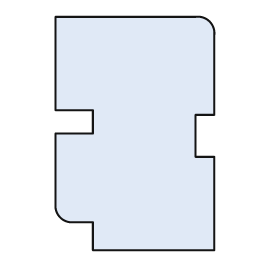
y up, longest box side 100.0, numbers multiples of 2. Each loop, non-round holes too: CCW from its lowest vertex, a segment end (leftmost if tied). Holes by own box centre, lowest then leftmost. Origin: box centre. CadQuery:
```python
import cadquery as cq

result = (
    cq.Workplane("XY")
    .moveTo(-18.0, -50.0)
    .lineTo(34.0, -50.0)
    .lineTo(34.0, -10.0)
    .lineTo(26.0, -10.0)
    .lineTo(26.0, 8.0)
    .lineTo(34.0, 8.0)
    .lineTo(34.0, 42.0)
    .threePointArc((32.0, 48.0), (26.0, 50.0))
    .lineTo(-34.0, 50.0)
    .lineTo(-34.0, 10.0)
    .lineTo(-18.0, 10.0)
    .lineTo(-18.0, 0.0)
    .lineTo(-34.0, 0.0)
    .lineTo(-34.0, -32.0)
    .threePointArc((-32.0, -36.0), (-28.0, -38.0))
    .lineTo(-18.0, -38.0)
    .close()
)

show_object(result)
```